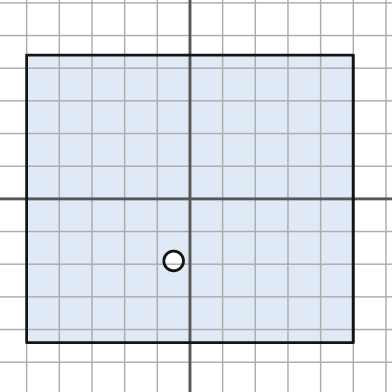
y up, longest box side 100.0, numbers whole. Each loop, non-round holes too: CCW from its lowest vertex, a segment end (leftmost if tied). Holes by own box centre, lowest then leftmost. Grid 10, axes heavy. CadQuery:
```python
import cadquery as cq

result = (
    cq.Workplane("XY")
    .moveTo(-50.0, -44.0)
    .lineTo(50.0, -44.0)
    .lineTo(50.0, 44.0)
    .lineTo(-50.0, 44.0)
    .close()
    .moveTo(-5.0, -19.0)
    .circle(3.0)
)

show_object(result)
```